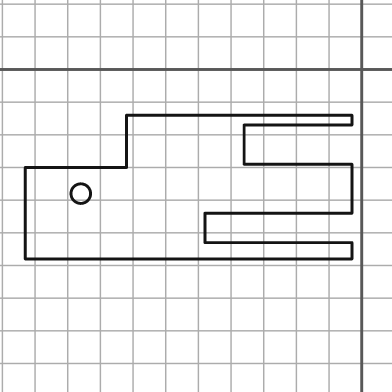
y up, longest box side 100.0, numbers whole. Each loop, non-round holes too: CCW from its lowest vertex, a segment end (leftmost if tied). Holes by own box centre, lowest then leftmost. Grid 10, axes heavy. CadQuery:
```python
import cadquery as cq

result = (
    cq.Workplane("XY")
    .moveTo(-103.0, -58.0)
    .lineTo(-3.0, -58.0)
    .lineTo(-3.0, -53.0)
    .lineTo(-48.0, -53.0)
    .lineTo(-48.0, -44.0)
    .lineTo(-3.0, -44.0)
    .lineTo(-3.0, -29.0)
    .lineTo(-36.0, -29.0)
    .lineTo(-36.0, -17.0)
    .lineTo(-3.0, -17.0)
    .lineTo(-3.0, -14.0)
    .lineTo(-72.0, -14.0)
    .lineTo(-72.0, -30.0)
    .lineTo(-103.0, -30.0)
    .close()
    .moveTo(-86.0, -38.0)
    .circle(3.0)
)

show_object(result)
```